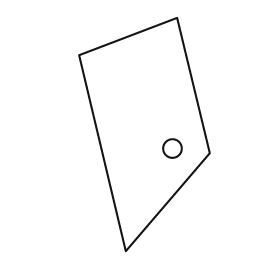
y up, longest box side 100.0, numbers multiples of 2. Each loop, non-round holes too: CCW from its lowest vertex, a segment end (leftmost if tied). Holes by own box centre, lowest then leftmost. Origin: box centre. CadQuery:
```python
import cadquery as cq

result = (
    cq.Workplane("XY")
    .moveTo(-8.0, -50.0)
    .lineTo(28.0, -8.0)
    .lineTo(14.0, 50.0)
    .lineTo(-28.0, 34.0)
    .close()
    .moveTo(12.0, -6.0)
    .circle(4.0)
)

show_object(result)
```